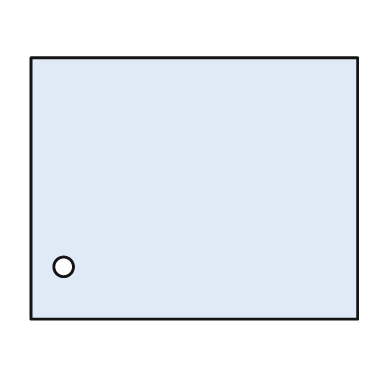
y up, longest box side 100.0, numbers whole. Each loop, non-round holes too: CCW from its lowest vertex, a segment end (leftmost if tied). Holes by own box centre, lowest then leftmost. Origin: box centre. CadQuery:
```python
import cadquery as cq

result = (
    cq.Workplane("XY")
    .moveTo(-50.0, -40.0)
    .lineTo(50.0, -40.0)
    .lineTo(50.0, 40.0)
    .lineTo(-50.0, 40.0)
    .close()
    .moveTo(-40.0, -24.0)
    .circle(3.0)
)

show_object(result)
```